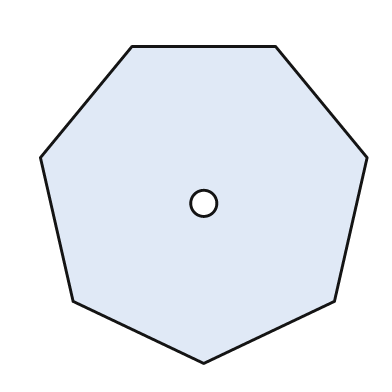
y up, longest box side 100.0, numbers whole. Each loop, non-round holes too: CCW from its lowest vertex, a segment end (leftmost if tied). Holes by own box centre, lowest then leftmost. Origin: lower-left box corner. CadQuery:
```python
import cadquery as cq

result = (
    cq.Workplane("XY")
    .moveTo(50.0, 0.0)
    .lineTo(90.0, 19.0)
    .lineTo(100.0, 63.0)
    .lineTo(72.0, 97.0)
    .lineTo(28.0, 97.0)
    .lineTo(0.0, 63.0)
    .lineTo(10.0, 19.0)
    .close()
    .moveTo(50.0, 49.0)
    .circle(4.0)
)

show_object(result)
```